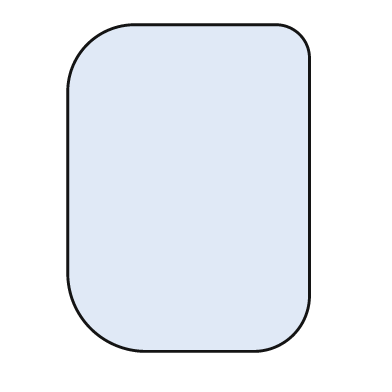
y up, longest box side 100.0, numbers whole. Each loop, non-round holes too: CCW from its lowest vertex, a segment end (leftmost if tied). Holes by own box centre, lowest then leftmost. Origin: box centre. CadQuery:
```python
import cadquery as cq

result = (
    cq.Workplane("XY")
    .moveTo(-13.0, -50.0)
    .lineTo(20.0, -50.0)
    .threePointArc((32.0, -45.0), (37.0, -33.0))
    .lineTo(37.0, 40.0)
    .threePointArc((34.0, 47.0), (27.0, 50.0))
    .lineTo(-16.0, 50.0)
    .threePointArc((-31.0, 44.0), (-37.0, 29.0))
    .lineTo(-37.0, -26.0)
    .threePointArc((-30.0, -43.0), (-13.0, -50.0))
    .close()
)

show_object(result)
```